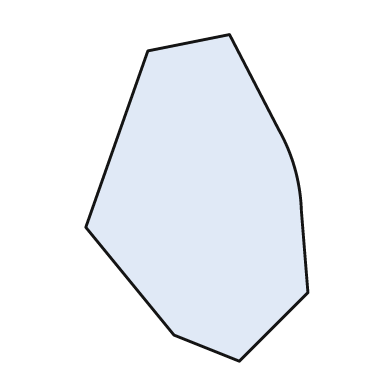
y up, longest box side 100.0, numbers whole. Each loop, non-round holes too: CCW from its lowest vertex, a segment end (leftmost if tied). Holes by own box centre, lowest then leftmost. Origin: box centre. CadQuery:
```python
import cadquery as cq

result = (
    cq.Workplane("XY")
    .moveTo(13.0, -50.0)
    .lineTo(34.0, -29.0)
    .lineTo(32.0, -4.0)
    .threePointArc((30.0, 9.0), (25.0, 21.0))
    .lineTo(10.0, 50.0)
    .lineTo(-15.0, 45.0)
    .lineTo(-34.0, -9.0)
    .lineTo(-7.0, -42.0)
    .close()
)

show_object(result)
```